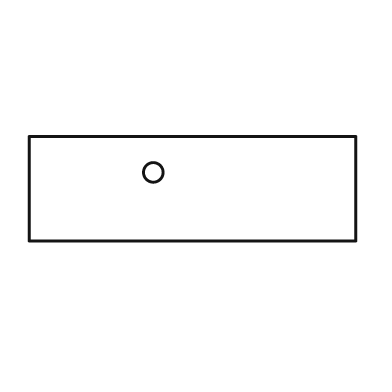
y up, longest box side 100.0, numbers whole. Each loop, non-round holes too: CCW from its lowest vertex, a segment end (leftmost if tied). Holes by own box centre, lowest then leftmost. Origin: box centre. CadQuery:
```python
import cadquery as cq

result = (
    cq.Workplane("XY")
    .moveTo(-50.0, -16.0)
    .lineTo(50.0, -16.0)
    .lineTo(50.0, 16.0)
    .lineTo(-50.0, 16.0)
    .close()
    .moveTo(-12.0, 5.0)
    .circle(3.0)
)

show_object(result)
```